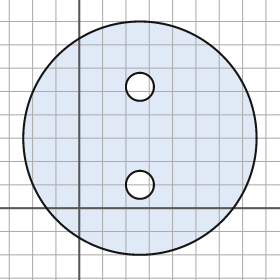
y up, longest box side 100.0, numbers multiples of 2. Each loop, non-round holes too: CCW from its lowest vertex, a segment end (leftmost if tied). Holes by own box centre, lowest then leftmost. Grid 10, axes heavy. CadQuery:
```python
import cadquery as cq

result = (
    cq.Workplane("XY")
    .moveTo(26.0, 30.0)
    .circle(50.0)
    .moveTo(26.0, 10.0)
    .circle(6.0)
    .moveTo(26.0, 52.0)
    .circle(6.0)
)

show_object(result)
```